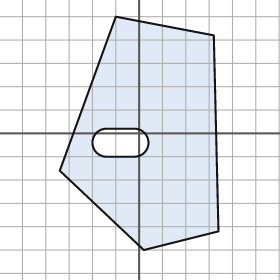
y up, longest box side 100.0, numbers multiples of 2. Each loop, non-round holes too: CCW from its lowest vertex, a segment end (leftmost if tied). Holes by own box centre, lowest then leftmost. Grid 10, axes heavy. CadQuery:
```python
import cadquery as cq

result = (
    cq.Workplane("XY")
    .moveTo(2.0, -50.0)
    .lineTo(34.0, -42.0)
    .lineTo(32.0, 42.0)
    .lineTo(-10.0, 50.0)
    .lineTo(-34.0, -16.0)
    .close()
    .moveTo(-14.0, -10.0)
    .lineTo(-2.0, -10.0)
    .threePointArc((4.0, -4.0), (-2.0, 2.0))
    .lineTo(-14.0, 2.0)
    .threePointArc((-20.0, -4.0), (-14.0, -10.0))
    .close()
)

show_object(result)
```